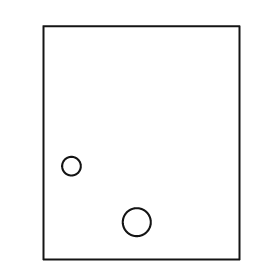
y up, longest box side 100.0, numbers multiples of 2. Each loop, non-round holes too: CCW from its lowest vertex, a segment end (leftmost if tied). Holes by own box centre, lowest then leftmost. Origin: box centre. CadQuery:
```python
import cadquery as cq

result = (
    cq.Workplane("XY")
    .moveTo(-42.0, -50.0)
    .lineTo(42.0, -50.0)
    .lineTo(42.0, 50.0)
    .lineTo(-42.0, 50.0)
    .close()
    .moveTo(-2.0, -34.0)
    .circle(6.0)
    .moveTo(-30.0, -10.0)
    .circle(4.0)
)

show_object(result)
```